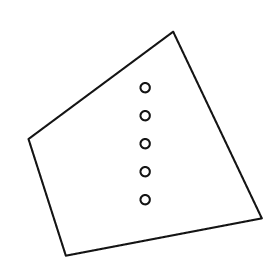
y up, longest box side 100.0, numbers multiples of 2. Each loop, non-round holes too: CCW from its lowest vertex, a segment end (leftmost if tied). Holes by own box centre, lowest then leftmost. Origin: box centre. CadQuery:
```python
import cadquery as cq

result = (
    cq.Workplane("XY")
    .moveTo(-34.0, -48.0)
    .lineTo(50.0, -32.0)
    .lineTo(12.0, 48.0)
    .lineTo(-50.0, 2.0)
    .close()
    .moveTo(0.0, -24.0)
    .circle(2.0)
    .moveTo(0.0, -12.0)
    .circle(2.0)
    .moveTo(0.0, 0.0)
    .circle(2.0)
    .moveTo(0.0, 12.0)
    .circle(2.0)
    .moveTo(0.0, 24.0)
    .circle(2.0)
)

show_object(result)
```